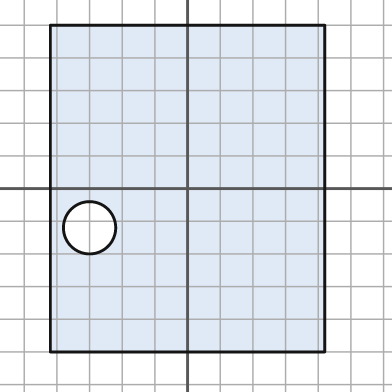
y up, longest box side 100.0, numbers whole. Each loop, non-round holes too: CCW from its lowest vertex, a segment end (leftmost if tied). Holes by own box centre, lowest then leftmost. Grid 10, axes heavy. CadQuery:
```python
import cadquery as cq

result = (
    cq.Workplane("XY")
    .moveTo(-42.0, -50.0)
    .lineTo(42.0, -50.0)
    .lineTo(42.0, 50.0)
    .lineTo(-42.0, 50.0)
    .close()
    .moveTo(-30.0, -12.0)
    .circle(8.0)
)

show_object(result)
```